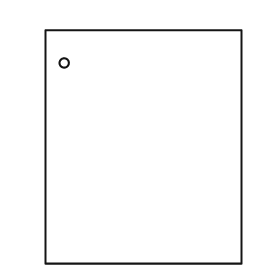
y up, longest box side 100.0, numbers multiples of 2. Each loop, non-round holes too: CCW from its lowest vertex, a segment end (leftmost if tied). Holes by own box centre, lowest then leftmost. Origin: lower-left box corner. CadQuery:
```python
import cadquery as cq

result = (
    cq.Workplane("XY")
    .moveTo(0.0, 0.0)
    .lineTo(84.0, 0.0)
    .lineTo(84.0, 100.0)
    .lineTo(0.0, 100.0)
    .close()
    .moveTo(8.0, 86.0)
    .circle(2.0)
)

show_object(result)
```